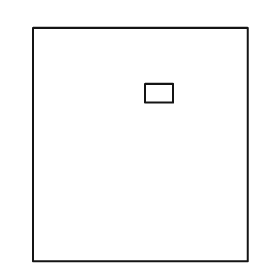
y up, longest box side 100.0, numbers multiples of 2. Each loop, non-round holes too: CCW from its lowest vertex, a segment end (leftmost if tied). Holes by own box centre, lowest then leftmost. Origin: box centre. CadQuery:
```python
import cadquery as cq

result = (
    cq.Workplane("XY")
    .moveTo(-46.0, -50.0)
    .lineTo(46.0, -50.0)
    .lineTo(46.0, 50.0)
    .lineTo(-46.0, 50.0)
    .close()
    .moveTo(2.0, 18.0)
    .lineTo(14.0, 18.0)
    .lineTo(14.0, 26.0)
    .lineTo(2.0, 26.0)
    .close()
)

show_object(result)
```